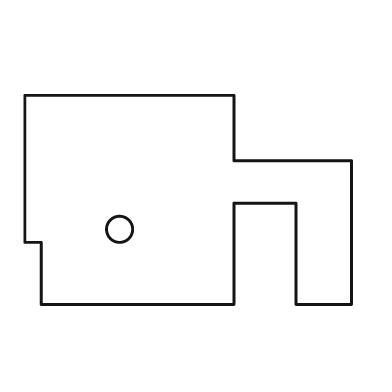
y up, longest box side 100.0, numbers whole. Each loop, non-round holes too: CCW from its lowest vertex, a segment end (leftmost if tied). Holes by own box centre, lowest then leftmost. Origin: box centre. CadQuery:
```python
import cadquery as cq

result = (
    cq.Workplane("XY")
    .moveTo(-45.0, -32.0)
    .lineTo(14.0, -32.0)
    .lineTo(14.0, -1.0)
    .lineTo(33.0, -1.0)
    .lineTo(33.0, -32.0)
    .lineTo(50.0, -32.0)
    .lineTo(50.0, 12.0)
    .lineTo(14.0, 12.0)
    .lineTo(14.0, 32.0)
    .lineTo(-50.0, 32.0)
    .lineTo(-50.0, -13.0)
    .lineTo(-45.0, -13.0)
    .close()
    .moveTo(-21.0, -9.0)
    .circle(4.0)
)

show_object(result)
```